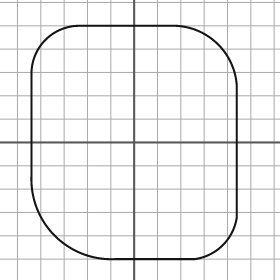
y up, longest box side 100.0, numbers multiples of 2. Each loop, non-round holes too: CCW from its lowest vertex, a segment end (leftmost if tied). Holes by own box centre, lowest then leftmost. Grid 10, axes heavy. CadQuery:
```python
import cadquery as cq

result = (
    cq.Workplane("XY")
    .moveTo(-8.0, -50.0)
    .lineTo(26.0, -50.0)
    .threePointArc((38.0, -44.0), (44.0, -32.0))
    .lineTo(44.0, 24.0)
    .threePointArc((36.0, 42.0), (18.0, 50.0))
    .lineTo(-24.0, 50.0)
    .threePointArc((-38.0, 44.0), (-44.0, 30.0))
    .lineTo(-44.0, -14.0)
    .threePointArc((-34.0, -40.0), (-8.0, -50.0))
    .close()
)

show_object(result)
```